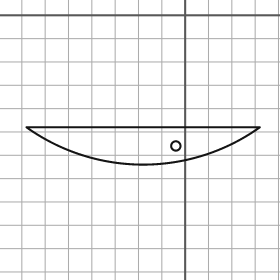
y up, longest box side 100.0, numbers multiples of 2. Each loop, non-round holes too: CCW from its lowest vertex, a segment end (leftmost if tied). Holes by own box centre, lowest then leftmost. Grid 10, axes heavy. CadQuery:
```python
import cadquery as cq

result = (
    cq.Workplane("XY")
    .moveTo(-68.0, -48.0)
    .threePointArc((-18.0, -64.0), (32.0, -48.0))
    .close()
    .moveTo(-4.0, -56.0)
    .circle(2.0)
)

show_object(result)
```